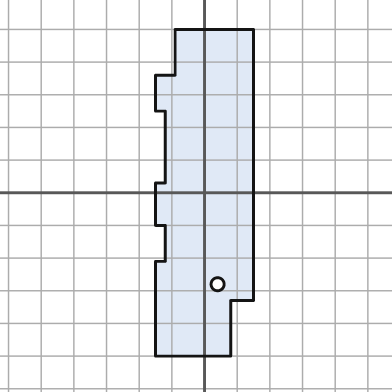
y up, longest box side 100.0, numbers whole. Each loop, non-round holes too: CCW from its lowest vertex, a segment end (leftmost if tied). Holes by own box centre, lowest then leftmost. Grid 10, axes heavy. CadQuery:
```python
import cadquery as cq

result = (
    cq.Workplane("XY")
    .moveTo(-15.0, -50.0)
    .lineTo(8.0, -50.0)
    .lineTo(8.0, -33.0)
    .lineTo(15.0, -33.0)
    .lineTo(15.0, 50.0)
    .lineTo(-9.0, 50.0)
    .lineTo(-9.0, 36.0)
    .lineTo(-15.0, 36.0)
    .lineTo(-15.0, 25.0)
    .lineTo(-12.0, 25.0)
    .lineTo(-12.0, 3.0)
    .lineTo(-15.0, 3.0)
    .lineTo(-15.0, -10.0)
    .lineTo(-12.0, -10.0)
    .lineTo(-12.0, -21.0)
    .lineTo(-15.0, -21.0)
    .close()
    .moveTo(4.0, -28.0)
    .circle(2.0)
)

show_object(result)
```